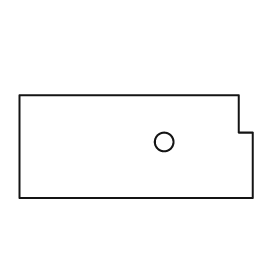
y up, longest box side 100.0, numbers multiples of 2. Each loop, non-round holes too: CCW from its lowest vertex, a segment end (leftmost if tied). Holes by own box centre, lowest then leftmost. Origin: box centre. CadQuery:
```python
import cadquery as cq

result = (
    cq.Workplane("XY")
    .moveTo(-50.0, -22.0)
    .lineTo(50.0, -22.0)
    .lineTo(50.0, 6.0)
    .lineTo(44.0, 6.0)
    .lineTo(44.0, 22.0)
    .lineTo(-50.0, 22.0)
    .close()
    .moveTo(12.0, 2.0)
    .circle(4.0)
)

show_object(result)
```